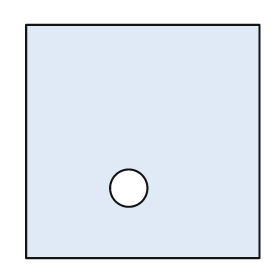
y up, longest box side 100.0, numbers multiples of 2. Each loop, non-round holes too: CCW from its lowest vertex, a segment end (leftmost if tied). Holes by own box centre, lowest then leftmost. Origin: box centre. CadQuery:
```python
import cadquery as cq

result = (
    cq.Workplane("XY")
    .moveTo(-50.0, -50.0)
    .lineTo(50.0, -50.0)
    .lineTo(50.0, 50.0)
    .lineTo(-50.0, 50.0)
    .close()
    .moveTo(-6.0, -20.0)
    .circle(8.0)
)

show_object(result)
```